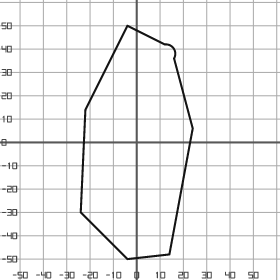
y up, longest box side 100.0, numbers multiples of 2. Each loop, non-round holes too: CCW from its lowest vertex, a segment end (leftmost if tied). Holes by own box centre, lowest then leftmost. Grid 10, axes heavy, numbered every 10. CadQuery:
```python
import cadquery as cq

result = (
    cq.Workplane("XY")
    .moveTo(-4.0, -50.0)
    .lineTo(14.0, -48.0)
    .lineTo(24.0, 6.0)
    .lineTo(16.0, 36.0)
    .threePointArc((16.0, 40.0), (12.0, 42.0))
    .lineTo(-4.0, 50.0)
    .lineTo(-22.0, 14.0)
    .lineTo(-24.0, -30.0)
    .close()
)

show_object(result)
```